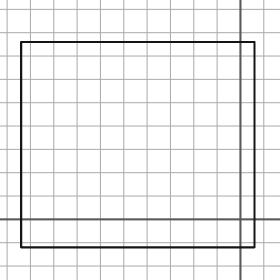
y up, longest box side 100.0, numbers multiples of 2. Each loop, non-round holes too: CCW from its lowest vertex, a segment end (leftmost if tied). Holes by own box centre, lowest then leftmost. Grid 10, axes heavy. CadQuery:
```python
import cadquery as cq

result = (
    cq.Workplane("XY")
    .moveTo(-94.0, -12.0)
    .lineTo(6.0, -12.0)
    .lineTo(6.0, 76.0)
    .lineTo(-94.0, 76.0)
    .close()
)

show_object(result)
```